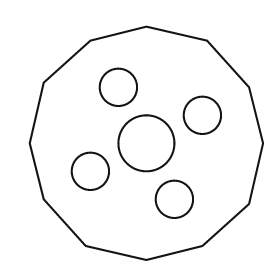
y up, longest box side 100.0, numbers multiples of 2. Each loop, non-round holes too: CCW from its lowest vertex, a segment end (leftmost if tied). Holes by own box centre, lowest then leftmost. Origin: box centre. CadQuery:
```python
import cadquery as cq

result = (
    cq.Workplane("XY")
    .moveTo(0.0, -50.0)
    .lineTo(24.0, -44.0)
    .lineTo(44.0, -26.0)
    .lineTo(50.0, 0.0)
    .lineTo(44.0, 24.0)
    .lineTo(26.0, 44.0)
    .lineTo(0.0, 50.0)
    .lineTo(-24.0, 44.0)
    .lineTo(-44.0, 26.0)
    .lineTo(-50.0, 0.0)
    .lineTo(-44.0, -24.0)
    .lineTo(-26.0, -44.0)
    .close()
    .moveTo(12.0, -24.0)
    .circle(8.0)
    .moveTo(-24.0, -12.0)
    .circle(8.0)
    .moveTo(0.0, 0.0)
    .circle(12.0)
    .moveTo(24.0, 12.0)
    .circle(8.0)
    .moveTo(-12.0, 24.0)
    .circle(8.0)
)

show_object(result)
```